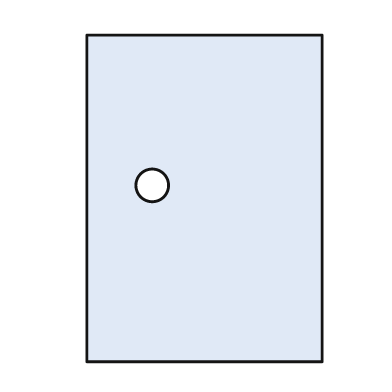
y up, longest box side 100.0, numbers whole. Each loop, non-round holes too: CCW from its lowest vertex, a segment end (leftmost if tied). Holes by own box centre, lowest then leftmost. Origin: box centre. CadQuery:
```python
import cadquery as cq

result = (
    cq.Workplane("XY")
    .moveTo(-36.0, -50.0)
    .lineTo(36.0, -50.0)
    .lineTo(36.0, 50.0)
    .lineTo(-36.0, 50.0)
    .close()
    .moveTo(-16.0, 4.0)
    .circle(5.0)
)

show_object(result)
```